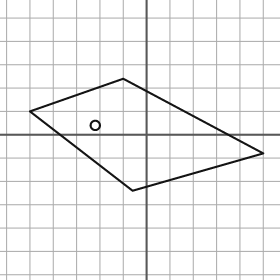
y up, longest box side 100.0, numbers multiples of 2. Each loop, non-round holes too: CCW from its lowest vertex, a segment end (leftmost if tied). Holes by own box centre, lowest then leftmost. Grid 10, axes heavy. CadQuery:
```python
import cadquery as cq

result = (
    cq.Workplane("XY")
    .moveTo(-6.0, -24.0)
    .lineTo(50.0, -8.0)
    .lineTo(-10.0, 24.0)
    .lineTo(-50.0, 10.0)
    .close()
    .moveTo(-22.0, 4.0)
    .circle(2.0)
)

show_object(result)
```